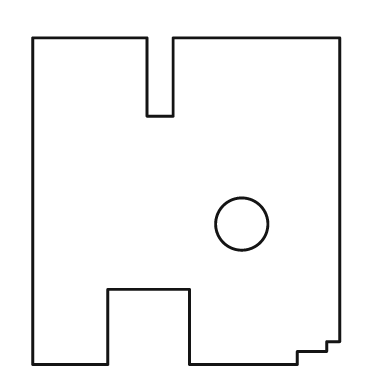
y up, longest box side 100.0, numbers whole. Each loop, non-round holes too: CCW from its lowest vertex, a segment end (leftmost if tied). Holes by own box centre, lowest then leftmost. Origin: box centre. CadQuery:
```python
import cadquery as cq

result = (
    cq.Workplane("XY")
    .moveTo(-47.0, -50.0)
    .lineTo(-24.0, -50.0)
    .lineTo(-24.0, -27.0)
    .lineTo(1.0, -27.0)
    .lineTo(1.0, -50.0)
    .lineTo(34.0, -50.0)
    .lineTo(34.0, -46.0)
    .lineTo(43.0, -46.0)
    .lineTo(43.0, -43.0)
    .lineTo(47.0, -43.0)
    .lineTo(47.0, 50.0)
    .lineTo(-4.0, 50.0)
    .lineTo(-4.0, 26.0)
    .lineTo(-12.0, 26.0)
    .lineTo(-12.0, 50.0)
    .lineTo(-47.0, 50.0)
    .close()
    .moveTo(17.0, -7.0)
    .circle(8.0)
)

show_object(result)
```